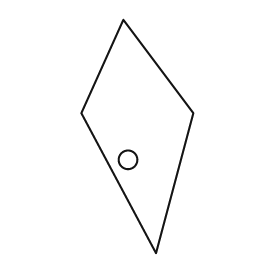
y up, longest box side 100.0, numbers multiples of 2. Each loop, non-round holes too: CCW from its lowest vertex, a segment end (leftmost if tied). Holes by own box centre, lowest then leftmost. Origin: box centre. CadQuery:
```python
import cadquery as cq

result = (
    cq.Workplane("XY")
    .moveTo(8.0, -50.0)
    .lineTo(24.0, 10.0)
    .lineTo(-6.0, 50.0)
    .lineTo(-24.0, 10.0)
    .close()
    .moveTo(-4.0, -10.0)
    .circle(4.0)
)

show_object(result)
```